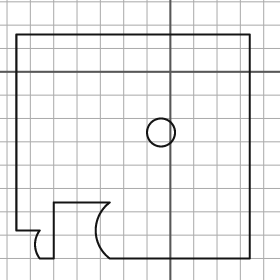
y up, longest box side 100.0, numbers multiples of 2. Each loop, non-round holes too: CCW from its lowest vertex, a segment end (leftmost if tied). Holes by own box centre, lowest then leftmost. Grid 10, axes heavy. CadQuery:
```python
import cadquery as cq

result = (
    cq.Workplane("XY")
    .moveTo(-56.0, -80.0)
    .lineTo(-50.0, -80.0)
    .lineTo(-50.0, -56.0)
    .lineTo(-26.0, -56.0)
    .threePointArc((-32.0, -68.0), (-26.0, -80.0))
    .lineTo(34.0, -80.0)
    .lineTo(34.0, 16.0)
    .lineTo(-66.0, 16.0)
    .lineTo(-66.0, -68.0)
    .lineTo(-56.0, -68.0)
    .threePointArc((-58.0, -74.0), (-56.0, -80.0))
    .close()
    .moveTo(-4.0, -26.0)
    .circle(6.0)
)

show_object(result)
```